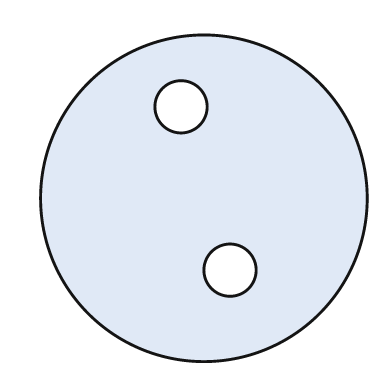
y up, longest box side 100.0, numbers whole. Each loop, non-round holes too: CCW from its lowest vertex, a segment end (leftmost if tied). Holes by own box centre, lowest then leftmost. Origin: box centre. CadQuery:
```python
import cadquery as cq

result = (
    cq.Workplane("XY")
    .moveTo(0.0, 0.0)
    .circle(50.0)
    .moveTo(8.0, -22.0)
    .circle(8.0)
    .moveTo(-7.0, 28.0)
    .circle(8.0)
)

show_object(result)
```